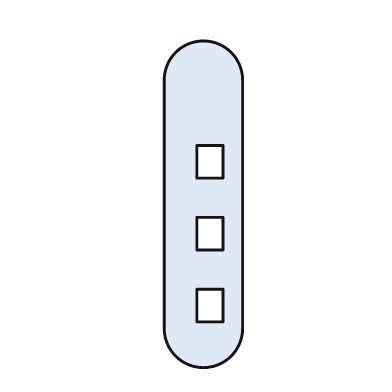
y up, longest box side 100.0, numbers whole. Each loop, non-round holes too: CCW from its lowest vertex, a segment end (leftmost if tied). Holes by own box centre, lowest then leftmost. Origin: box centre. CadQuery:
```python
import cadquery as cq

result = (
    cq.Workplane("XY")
    .moveTo(-12.0, -38.0)
    .threePointArc((0.0, -50.0), (12.0, -38.0))
    .lineTo(12.0, 38.0)
    .threePointArc((0.0, 50.0), (-12.0, 38.0))
    .close()
    .moveTo(-2.0, -36.0)
    .lineTo(6.0, -36.0)
    .lineTo(6.0, -26.0)
    .lineTo(-2.0, -26.0)
    .close()
    .moveTo(-2.0, -14.0)
    .lineTo(6.0, -14.0)
    .lineTo(6.0, -4.0)
    .lineTo(-2.0, -4.0)
    .close()
    .moveTo(-2.0, 8.0)
    .lineTo(6.0, 8.0)
    .lineTo(6.0, 18.0)
    .lineTo(-2.0, 18.0)
    .close()
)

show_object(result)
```